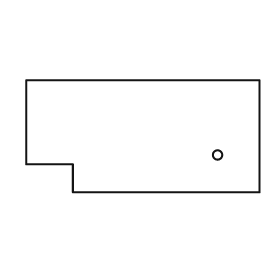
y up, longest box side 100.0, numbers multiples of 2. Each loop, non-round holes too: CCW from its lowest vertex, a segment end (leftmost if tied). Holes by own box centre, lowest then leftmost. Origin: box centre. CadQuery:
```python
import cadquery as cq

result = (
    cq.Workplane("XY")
    .moveTo(-30.0, -24.0)
    .lineTo(50.0, -24.0)
    .lineTo(50.0, 24.0)
    .lineTo(-50.0, 24.0)
    .lineTo(-50.0, -12.0)
    .lineTo(-30.0, -12.0)
    .close()
    .moveTo(32.0, -8.0)
    .circle(2.0)
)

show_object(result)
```